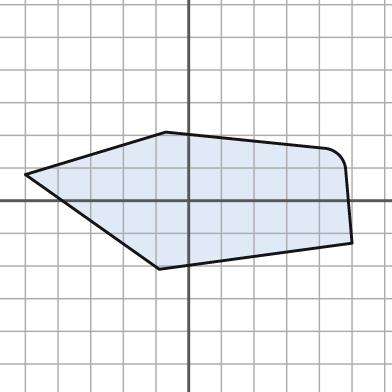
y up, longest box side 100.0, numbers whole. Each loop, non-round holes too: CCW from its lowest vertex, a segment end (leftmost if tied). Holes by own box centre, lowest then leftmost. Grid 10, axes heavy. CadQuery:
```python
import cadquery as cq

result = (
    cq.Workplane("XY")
    .moveTo(-9.0, -21.0)
    .lineTo(50.0, -13.0)
    .lineTo(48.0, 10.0)
    .threePointArc((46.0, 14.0), (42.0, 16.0))
    .lineTo(-7.0, 21.0)
    .lineTo(-50.0, 8.0)
    .close()
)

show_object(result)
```